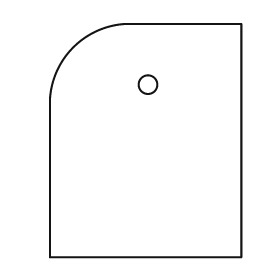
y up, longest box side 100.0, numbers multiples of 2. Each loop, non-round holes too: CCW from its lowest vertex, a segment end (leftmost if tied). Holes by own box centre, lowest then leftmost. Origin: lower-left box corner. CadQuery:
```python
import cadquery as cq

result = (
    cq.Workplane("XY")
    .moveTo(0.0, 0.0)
    .lineTo(82.0, 0.0)
    .lineTo(82.0, 100.0)
    .lineTo(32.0, 100.0)
    .threePointArc((10.0, 90.0), (0.0, 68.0))
    .close()
    .moveTo(42.0, 74.0)
    .circle(4.0)
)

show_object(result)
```